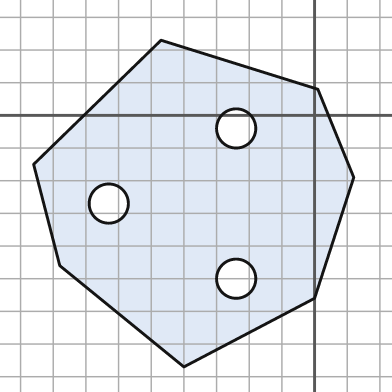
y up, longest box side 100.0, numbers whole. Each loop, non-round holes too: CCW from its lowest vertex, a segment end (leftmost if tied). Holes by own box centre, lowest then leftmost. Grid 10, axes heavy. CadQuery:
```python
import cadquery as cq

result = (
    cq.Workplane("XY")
    .moveTo(-40.0, -77.0)
    .lineTo(0.0, -56.0)
    .lineTo(12.0, -19.0)
    .lineTo(1.0, 8.0)
    .lineTo(-47.0, 23.0)
    .lineTo(-86.0, -15.0)
    .lineTo(-78.0, -46.0)
    .close()
    .moveTo(-24.0, -50.0)
    .circle(6.0)
    .moveTo(-63.0, -27.0)
    .circle(6.0)
    .moveTo(-24.0, -4.0)
    .circle(6.0)
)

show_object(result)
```